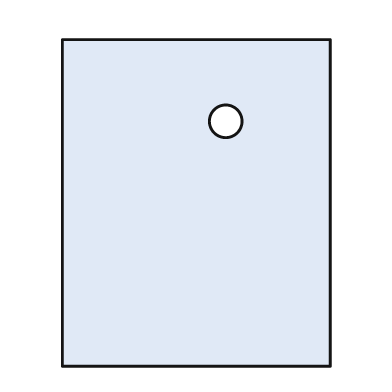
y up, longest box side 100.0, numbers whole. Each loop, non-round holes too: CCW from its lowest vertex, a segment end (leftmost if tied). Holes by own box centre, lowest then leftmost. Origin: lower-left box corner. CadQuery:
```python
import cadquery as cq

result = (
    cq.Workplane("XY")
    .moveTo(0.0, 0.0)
    .lineTo(82.0, 0.0)
    .lineTo(82.0, 100.0)
    .lineTo(0.0, 100.0)
    .close()
    .moveTo(50.0, 75.0)
    .circle(5.0)
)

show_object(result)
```